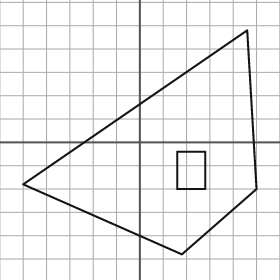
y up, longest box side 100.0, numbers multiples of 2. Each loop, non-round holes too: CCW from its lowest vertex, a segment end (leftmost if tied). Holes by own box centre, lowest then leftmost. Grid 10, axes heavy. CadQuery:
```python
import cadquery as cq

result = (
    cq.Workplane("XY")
    .moveTo(18.0, -48.0)
    .lineTo(50.0, -20.0)
    .lineTo(46.0, 48.0)
    .lineTo(-50.0, -18.0)
    .close()
    .moveTo(16.0, -20.0)
    .lineTo(28.0, -20.0)
    .lineTo(28.0, -4.0)
    .lineTo(16.0, -4.0)
    .close()
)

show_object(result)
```